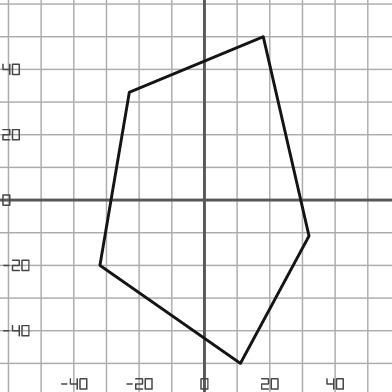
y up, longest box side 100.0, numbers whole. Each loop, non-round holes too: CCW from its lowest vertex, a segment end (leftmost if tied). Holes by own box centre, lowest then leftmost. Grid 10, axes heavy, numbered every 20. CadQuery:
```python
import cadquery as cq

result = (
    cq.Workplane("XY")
    .moveTo(11.0, -50.0)
    .lineTo(32.0, -11.0)
    .lineTo(18.0, 50.0)
    .lineTo(-23.0, 33.0)
    .lineTo(-32.0, -20.0)
    .close()
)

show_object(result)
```